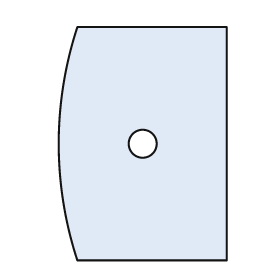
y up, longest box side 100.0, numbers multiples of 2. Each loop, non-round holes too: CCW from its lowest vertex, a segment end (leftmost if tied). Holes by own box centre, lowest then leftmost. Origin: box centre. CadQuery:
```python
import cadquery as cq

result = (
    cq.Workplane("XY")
    .moveTo(-28.0, -50.0)
    .lineTo(36.0, -50.0)
    .lineTo(36.0, 50.0)
    .lineTo(-28.0, 50.0)
    .threePointArc((-36.0, 0.0), (-28.0, -50.0))
    .close()
    .moveTo(0.0, 0.0)
    .circle(6.0)
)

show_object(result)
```